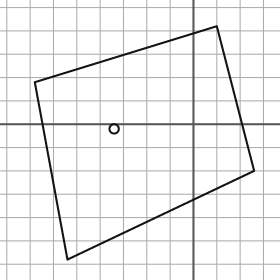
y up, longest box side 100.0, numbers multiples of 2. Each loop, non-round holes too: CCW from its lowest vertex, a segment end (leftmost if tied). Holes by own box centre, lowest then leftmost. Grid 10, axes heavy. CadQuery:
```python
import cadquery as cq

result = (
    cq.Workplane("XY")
    .moveTo(-54.0, -58.0)
    .lineTo(26.0, -20.0)
    .lineTo(10.0, 42.0)
    .lineTo(-68.0, 18.0)
    .close()
    .moveTo(-34.0, -2.0)
    .circle(2.0)
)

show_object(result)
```